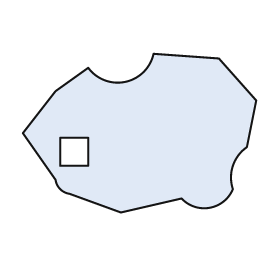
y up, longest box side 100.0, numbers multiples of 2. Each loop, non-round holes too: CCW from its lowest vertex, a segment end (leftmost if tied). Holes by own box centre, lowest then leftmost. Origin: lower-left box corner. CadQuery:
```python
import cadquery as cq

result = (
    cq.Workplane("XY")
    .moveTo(42.0, 0.0)
    .lineTo(68.0, 6.0)
    .threePointArc((80.0, 2.0), (90.0, 10.0))
    .threePointArc((90.0, 20.0), (96.0, 28.0))
    .lineTo(100.0, 48.0)
    .lineTo(84.0, 66.0)
    .lineTo(56.0, 68.0)
    .threePointArc((44.0, 56.0), (28.0, 62.0))
    .lineTo(14.0, 52.0)
    .lineTo(0.0, 34.0)
    .lineTo(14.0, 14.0)
    .threePointArc((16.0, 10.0), (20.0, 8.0))
    .close()
    .moveTo(16.0, 20.0)
    .lineTo(28.0, 20.0)
    .lineTo(28.0, 32.0)
    .lineTo(16.0, 32.0)
    .close()
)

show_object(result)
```